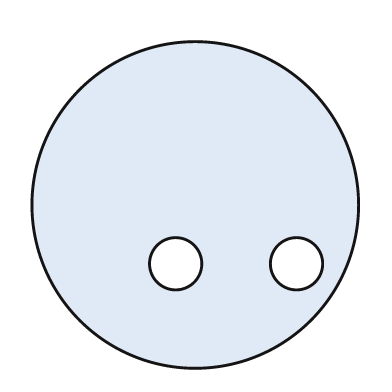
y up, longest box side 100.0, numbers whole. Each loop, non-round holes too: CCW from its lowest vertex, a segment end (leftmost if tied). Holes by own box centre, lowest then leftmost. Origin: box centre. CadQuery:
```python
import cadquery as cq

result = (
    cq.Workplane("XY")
    .moveTo(0.0, 0.0)
    .circle(50.0)
    .moveTo(-6.0, -18.0)
    .circle(8.0)
    .moveTo(31.0, -18.0)
    .circle(8.0)
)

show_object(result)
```